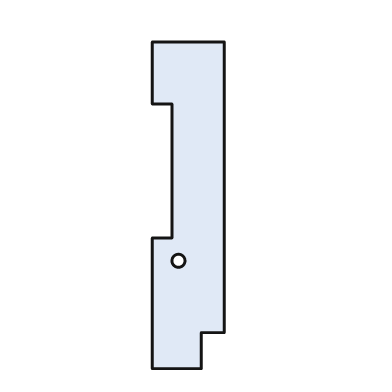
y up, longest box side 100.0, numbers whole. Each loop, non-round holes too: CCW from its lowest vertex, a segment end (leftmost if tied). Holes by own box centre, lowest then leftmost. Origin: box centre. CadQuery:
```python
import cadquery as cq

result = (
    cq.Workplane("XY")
    .moveTo(-11.0, -50.0)
    .lineTo(4.0, -50.0)
    .lineTo(4.0, -39.0)
    .lineTo(11.0, -39.0)
    .lineTo(11.0, 50.0)
    .lineTo(-11.0, 50.0)
    .lineTo(-11.0, 31.0)
    .lineTo(-5.0, 31.0)
    .lineTo(-5.0, -10.0)
    .lineTo(-11.0, -10.0)
    .close()
    .moveTo(-3.0, -17.0)
    .circle(2.0)
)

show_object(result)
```